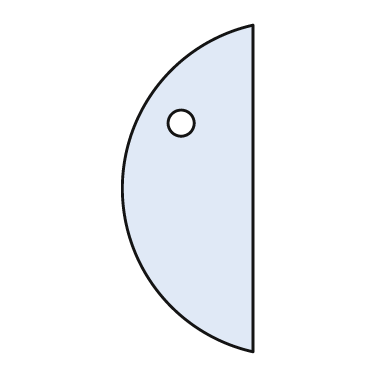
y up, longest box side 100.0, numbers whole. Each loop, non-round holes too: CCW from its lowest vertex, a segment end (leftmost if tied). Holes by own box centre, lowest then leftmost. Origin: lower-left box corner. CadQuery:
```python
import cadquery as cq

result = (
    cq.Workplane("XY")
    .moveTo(40.0, 0.0)
    .lineTo(40.0, 100.0)
    .threePointArc((0.0, 50.0), (40.0, 0.0))
    .close()
    .moveTo(18.0, 70.0)
    .circle(4.0)
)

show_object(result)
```